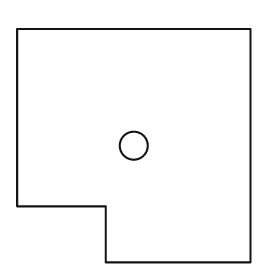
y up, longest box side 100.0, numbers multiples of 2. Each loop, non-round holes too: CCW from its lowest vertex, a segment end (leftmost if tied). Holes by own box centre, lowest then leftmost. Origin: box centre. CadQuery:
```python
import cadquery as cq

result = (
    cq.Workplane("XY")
    .moveTo(-12.0, -50.0)
    .lineTo(50.0, -50.0)
    .lineTo(50.0, 50.0)
    .lineTo(-50.0, 50.0)
    .lineTo(-50.0, -26.0)
    .lineTo(-12.0, -26.0)
    .close()
    .moveTo(0.0, 0.0)
    .circle(6.0)
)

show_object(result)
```